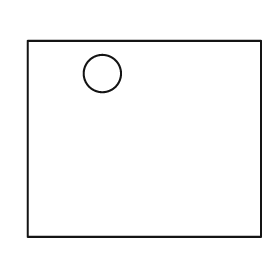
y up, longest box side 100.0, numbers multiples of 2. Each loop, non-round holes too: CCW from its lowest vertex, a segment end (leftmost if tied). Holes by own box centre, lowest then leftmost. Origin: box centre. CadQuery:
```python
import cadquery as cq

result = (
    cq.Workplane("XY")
    .moveTo(-50.0, -42.0)
    .lineTo(50.0, -42.0)
    .lineTo(50.0, 42.0)
    .lineTo(-50.0, 42.0)
    .close()
    .moveTo(-18.0, 28.0)
    .circle(8.0)
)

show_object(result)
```